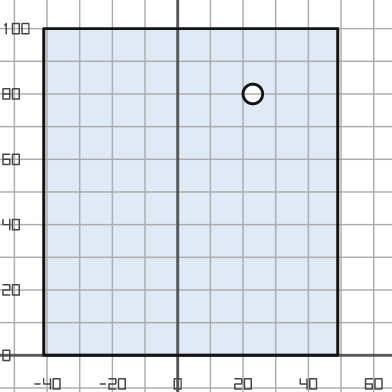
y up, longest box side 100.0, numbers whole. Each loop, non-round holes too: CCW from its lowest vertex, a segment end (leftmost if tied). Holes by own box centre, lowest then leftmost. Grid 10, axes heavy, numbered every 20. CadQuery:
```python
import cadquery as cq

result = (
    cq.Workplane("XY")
    .moveTo(-41.0, 0.0)
    .lineTo(49.0, 0.0)
    .lineTo(49.0, 100.0)
    .lineTo(-41.0, 100.0)
    .close()
    .moveTo(23.0, 80.0)
    .circle(3.0)
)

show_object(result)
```